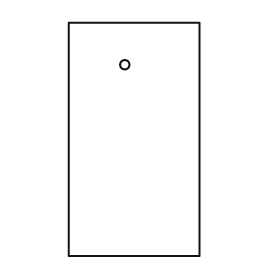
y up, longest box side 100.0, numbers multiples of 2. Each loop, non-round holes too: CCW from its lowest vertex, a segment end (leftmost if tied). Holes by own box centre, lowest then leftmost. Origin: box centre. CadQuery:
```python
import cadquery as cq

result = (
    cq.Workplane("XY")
    .moveTo(-28.0, -50.0)
    .lineTo(28.0, -50.0)
    .lineTo(28.0, 50.0)
    .lineTo(-28.0, 50.0)
    .close()
    .moveTo(-4.0, 32.0)
    .circle(2.0)
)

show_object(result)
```